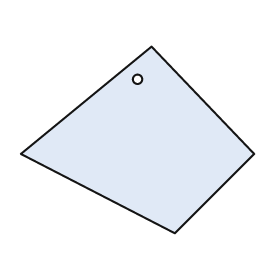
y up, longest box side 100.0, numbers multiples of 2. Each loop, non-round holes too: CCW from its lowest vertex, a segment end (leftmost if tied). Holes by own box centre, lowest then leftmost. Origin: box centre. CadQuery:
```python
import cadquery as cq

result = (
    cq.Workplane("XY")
    .moveTo(16.0, -40.0)
    .lineTo(50.0, -6.0)
    .lineTo(6.0, 40.0)
    .lineTo(-50.0, -6.0)
    .close()
    .moveTo(0.0, 26.0)
    .circle(2.0)
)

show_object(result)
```